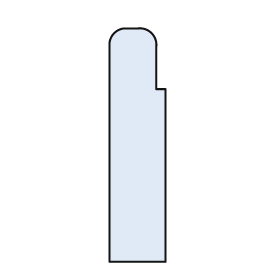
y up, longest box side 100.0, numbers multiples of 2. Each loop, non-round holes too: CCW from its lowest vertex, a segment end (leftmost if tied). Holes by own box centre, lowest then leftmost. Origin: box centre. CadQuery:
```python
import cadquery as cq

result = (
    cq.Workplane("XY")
    .moveTo(-12.0, -50.0)
    .lineTo(12.0, -50.0)
    .lineTo(12.0, 24.0)
    .lineTo(8.0, 24.0)
    .lineTo(8.0, 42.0)
    .threePointArc((6.0, 48.0), (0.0, 50.0))
    .lineTo(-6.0, 50.0)
    .threePointArc((-10.0, 48.0), (-12.0, 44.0))
    .close()
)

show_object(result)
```